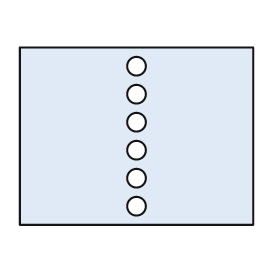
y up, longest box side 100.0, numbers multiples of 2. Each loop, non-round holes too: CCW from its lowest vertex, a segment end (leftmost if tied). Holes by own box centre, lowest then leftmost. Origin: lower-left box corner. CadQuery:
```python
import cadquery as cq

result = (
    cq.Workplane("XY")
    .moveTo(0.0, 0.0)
    .lineTo(100.0, 0.0)
    .lineTo(100.0, 76.0)
    .lineTo(0.0, 76.0)
    .close()
    .moveTo(50.0, 8.0)
    .circle(4.0)
    .moveTo(50.0, 20.0)
    .circle(4.0)
    .moveTo(50.0, 32.0)
    .circle(4.0)
    .moveTo(50.0, 44.0)
    .circle(4.0)
    .moveTo(50.0, 56.0)
    .circle(4.0)
    .moveTo(50.0, 68.0)
    .circle(4.0)
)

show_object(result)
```